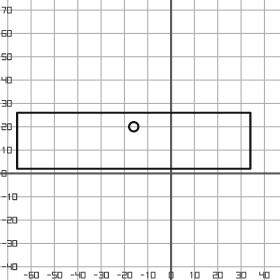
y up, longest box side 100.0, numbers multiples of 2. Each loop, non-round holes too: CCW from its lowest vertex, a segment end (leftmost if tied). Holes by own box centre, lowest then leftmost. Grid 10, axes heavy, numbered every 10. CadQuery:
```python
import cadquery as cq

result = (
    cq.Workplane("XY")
    .moveTo(-66.0, 2.0)
    .lineTo(34.0, 2.0)
    .lineTo(34.0, 26.0)
    .lineTo(-66.0, 26.0)
    .close()
    .moveTo(-16.0, 20.0)
    .circle(2.0)
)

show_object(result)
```